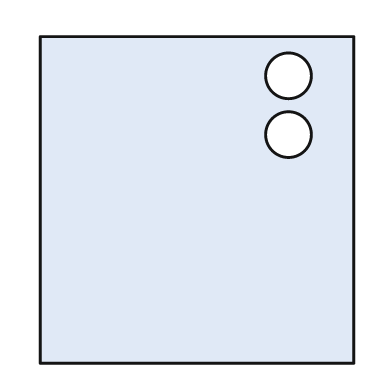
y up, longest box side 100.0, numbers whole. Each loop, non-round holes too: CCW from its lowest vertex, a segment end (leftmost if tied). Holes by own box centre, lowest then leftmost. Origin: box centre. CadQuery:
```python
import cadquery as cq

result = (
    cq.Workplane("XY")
    .moveTo(-48.0, -50.0)
    .lineTo(48.0, -50.0)
    .lineTo(48.0, 50.0)
    .lineTo(-48.0, 50.0)
    .close()
    .moveTo(28.0, 20.0)
    .circle(7.0)
    .moveTo(28.0, 38.0)
    .circle(7.0)
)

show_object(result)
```